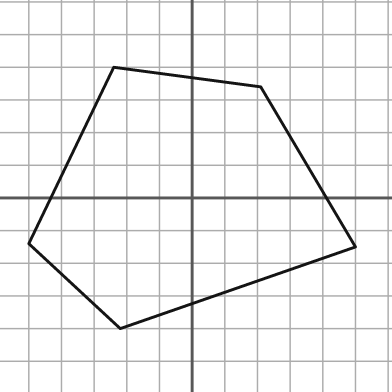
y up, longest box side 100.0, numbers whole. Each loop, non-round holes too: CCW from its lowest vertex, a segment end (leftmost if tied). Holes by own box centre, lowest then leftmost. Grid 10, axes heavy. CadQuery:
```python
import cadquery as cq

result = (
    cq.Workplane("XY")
    .moveTo(-22.0, -40.0)
    .lineTo(50.0, -15.0)
    .lineTo(21.0, 34.0)
    .lineTo(-24.0, 40.0)
    .lineTo(-50.0, -14.0)
    .close()
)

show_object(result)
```